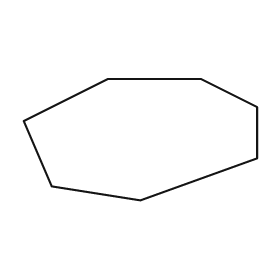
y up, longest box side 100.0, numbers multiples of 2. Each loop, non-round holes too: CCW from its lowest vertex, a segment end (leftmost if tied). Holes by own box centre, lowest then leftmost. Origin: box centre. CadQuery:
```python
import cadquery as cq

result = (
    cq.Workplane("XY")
    .moveTo(0.0, -26.0)
    .lineTo(50.0, -8.0)
    .lineTo(50.0, 14.0)
    .lineTo(26.0, 26.0)
    .lineTo(-14.0, 26.0)
    .lineTo(-50.0, 8.0)
    .lineTo(-38.0, -20.0)
    .close()
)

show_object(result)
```